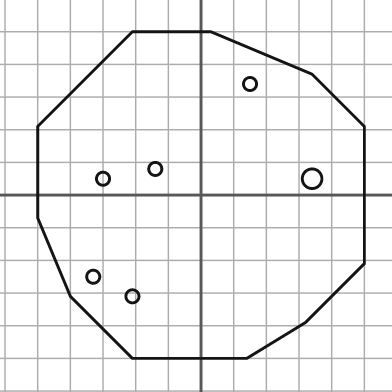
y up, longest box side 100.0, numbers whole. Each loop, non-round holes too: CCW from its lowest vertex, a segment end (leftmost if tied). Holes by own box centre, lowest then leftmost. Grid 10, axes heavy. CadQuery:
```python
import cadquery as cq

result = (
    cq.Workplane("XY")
    .moveTo(-21.0, -50.0)
    .lineTo(14.0, -50.0)
    .lineTo(32.0, -39.0)
    .lineTo(50.0, -21.0)
    .lineTo(50.0, 21.0)
    .lineTo(34.0, 37.0)
    .lineTo(3.0, 50.0)
    .lineTo(-21.0, 50.0)
    .lineTo(-50.0, 21.0)
    .lineTo(-50.0, -7.0)
    .lineTo(-40.0, -31.0)
    .close()
    .moveTo(-21.0, -31.0)
    .circle(2.0)
    .moveTo(-33.0, -25.0)
    .circle(2.0)
    .moveTo(-30.0, 5.0)
    .circle(2.0)
    .moveTo(34.0, 5.0)
    .circle(3.0)
    .moveTo(-14.0, 8.0)
    .circle(2.0)
    .moveTo(15.0, 34.0)
    .circle(2.0)
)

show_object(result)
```